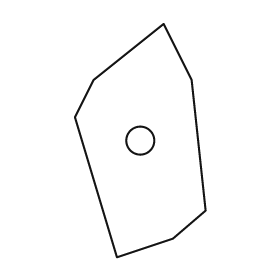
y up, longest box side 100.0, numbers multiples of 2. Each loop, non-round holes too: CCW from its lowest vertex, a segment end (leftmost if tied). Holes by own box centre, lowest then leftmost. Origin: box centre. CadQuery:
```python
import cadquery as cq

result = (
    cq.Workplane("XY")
    .moveTo(-10.0, -50.0)
    .lineTo(14.0, -42.0)
    .lineTo(28.0, -30.0)
    .lineTo(22.0, 26.0)
    .lineTo(10.0, 50.0)
    .lineTo(-20.0, 26.0)
    .lineTo(-28.0, 10.0)
    .close()
    .moveTo(0.0, 0.0)
    .circle(6.0)
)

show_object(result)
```